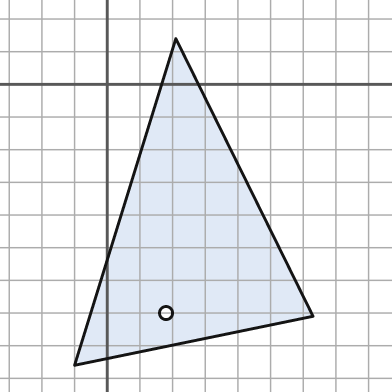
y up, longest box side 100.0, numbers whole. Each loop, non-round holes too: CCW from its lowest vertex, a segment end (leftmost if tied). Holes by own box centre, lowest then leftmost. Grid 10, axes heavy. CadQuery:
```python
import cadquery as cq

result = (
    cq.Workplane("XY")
    .moveTo(-10.0, -86.0)
    .lineTo(63.0, -71.0)
    .lineTo(21.0, 14.0)
    .close()
    .moveTo(18.0, -70.0)
    .circle(2.0)
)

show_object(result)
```